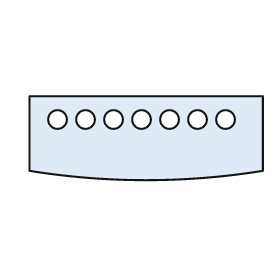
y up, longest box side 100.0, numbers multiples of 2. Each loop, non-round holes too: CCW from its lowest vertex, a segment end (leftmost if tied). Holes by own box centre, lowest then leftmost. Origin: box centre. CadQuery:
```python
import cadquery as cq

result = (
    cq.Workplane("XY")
    .moveTo(-50.0, -14.0)
    .threePointArc((0.0, -18.0), (50.0, -14.0))
    .lineTo(50.0, 18.0)
    .lineTo(-50.0, 18.0)
    .close()
    .moveTo(-38.0, 8.0)
    .circle(4.0)
    .moveTo(-26.0, 8.0)
    .circle(4.0)
    .moveTo(-14.0, 8.0)
    .circle(4.0)
    .moveTo(-2.0, 8.0)
    .circle(4.0)
    .moveTo(10.0, 8.0)
    .circle(4.0)
    .moveTo(22.0, 8.0)
    .circle(4.0)
    .moveTo(34.0, 8.0)
    .circle(4.0)
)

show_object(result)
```